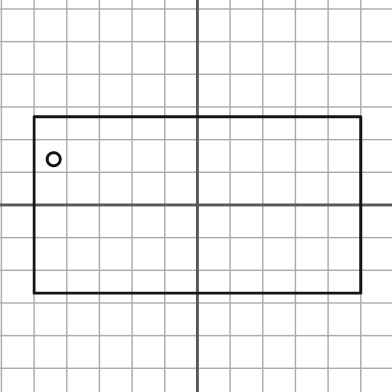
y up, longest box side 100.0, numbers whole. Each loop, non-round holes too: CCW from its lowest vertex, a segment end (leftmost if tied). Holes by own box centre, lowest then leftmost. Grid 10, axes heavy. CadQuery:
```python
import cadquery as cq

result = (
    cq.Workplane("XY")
    .moveTo(-50.0, -27.0)
    .lineTo(50.0, -27.0)
    .lineTo(50.0, 27.0)
    .lineTo(-50.0, 27.0)
    .close()
    .moveTo(-44.0, 14.0)
    .circle(2.0)
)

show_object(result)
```